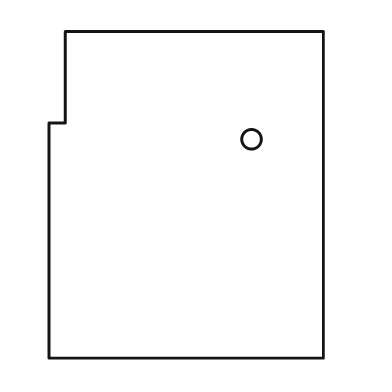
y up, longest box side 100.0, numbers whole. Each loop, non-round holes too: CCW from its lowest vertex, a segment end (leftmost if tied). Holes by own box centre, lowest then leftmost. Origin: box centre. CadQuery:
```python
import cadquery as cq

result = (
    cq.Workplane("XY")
    .moveTo(-42.0, -50.0)
    .lineTo(42.0, -50.0)
    .lineTo(42.0, 50.0)
    .lineTo(-37.0, 50.0)
    .lineTo(-37.0, 22.0)
    .lineTo(-42.0, 22.0)
    .close()
    .moveTo(20.0, 17.0)
    .circle(3.0)
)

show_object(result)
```